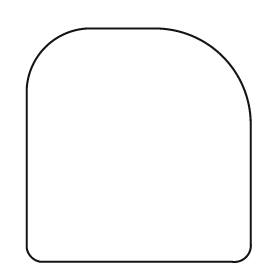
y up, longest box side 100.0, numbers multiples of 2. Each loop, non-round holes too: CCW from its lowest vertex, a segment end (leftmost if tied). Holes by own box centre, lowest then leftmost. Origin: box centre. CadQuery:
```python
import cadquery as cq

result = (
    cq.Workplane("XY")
    .moveTo(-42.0, -50.0)
    .lineTo(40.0, -50.0)
    .threePointArc((46.0, -48.0), (48.0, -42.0))
    .lineTo(48.0, 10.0)
    .threePointArc((36.0, 38.0), (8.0, 50.0))
    .lineTo(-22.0, 50.0)
    .threePointArc((-40.0, 42.0), (-48.0, 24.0))
    .lineTo(-48.0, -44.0)
    .threePointArc((-46.0, -48.0), (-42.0, -50.0))
    .close()
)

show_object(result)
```